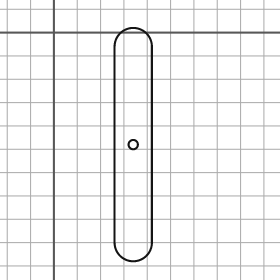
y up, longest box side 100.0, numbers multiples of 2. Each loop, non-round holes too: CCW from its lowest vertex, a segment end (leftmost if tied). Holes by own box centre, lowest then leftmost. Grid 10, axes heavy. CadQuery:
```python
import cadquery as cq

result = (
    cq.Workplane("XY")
    .moveTo(26.0, -90.0)
    .threePointArc((34.0, -98.0), (42.0, -90.0))
    .lineTo(42.0, -6.0)
    .threePointArc((34.0, 2.0), (26.0, -6.0))
    .close()
    .moveTo(34.0, -48.0)
    .circle(2.0)
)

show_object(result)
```